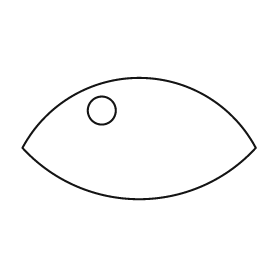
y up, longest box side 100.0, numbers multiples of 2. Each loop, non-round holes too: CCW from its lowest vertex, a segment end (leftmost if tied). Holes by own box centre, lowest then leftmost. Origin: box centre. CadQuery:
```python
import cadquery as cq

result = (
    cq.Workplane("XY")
    .moveTo(-50.0, -4.0)
    .threePointArc((0.0, -26.0), (50.0, -4.0))
    .threePointArc((0.0, 26.0), (-50.0, -4.0))
    .close()
    .moveTo(-16.0, 12.0)
    .circle(6.0)
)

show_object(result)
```